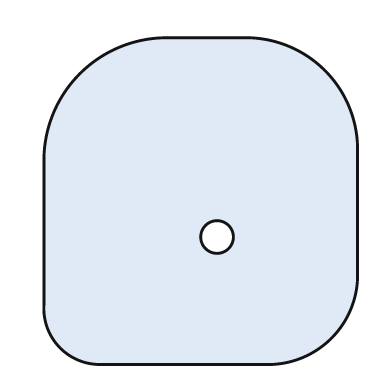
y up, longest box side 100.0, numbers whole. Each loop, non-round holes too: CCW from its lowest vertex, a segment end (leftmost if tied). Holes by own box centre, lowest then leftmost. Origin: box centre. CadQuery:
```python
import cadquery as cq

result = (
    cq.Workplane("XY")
    .moveTo(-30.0, -50.0)
    .lineTo(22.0, -50.0)
    .threePointArc((40.0, -42.0), (48.0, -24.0))
    .lineTo(48.0, 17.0)
    .threePointArc((38.0, 40.0), (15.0, 50.0))
    .lineTo(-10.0, 50.0)
    .threePointArc((-37.0, 39.0), (-48.0, 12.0))
    .lineTo(-48.0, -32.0)
    .threePointArc((-43.0, -45.0), (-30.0, -50.0))
    .close()
    .moveTo(5.0, -11.0)
    .circle(5.0)
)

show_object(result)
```